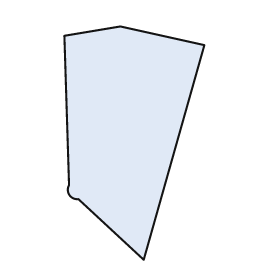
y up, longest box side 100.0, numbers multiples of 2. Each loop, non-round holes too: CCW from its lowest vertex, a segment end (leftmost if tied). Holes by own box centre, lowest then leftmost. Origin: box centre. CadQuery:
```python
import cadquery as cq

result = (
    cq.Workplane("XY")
    .moveTo(4.0, -50.0)
    .lineTo(30.0, 42.0)
    .lineTo(-6.0, 50.0)
    .lineTo(-30.0, 46.0)
    .lineTo(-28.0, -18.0)
    .threePointArc((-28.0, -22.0), (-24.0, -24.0))
    .close()
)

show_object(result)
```